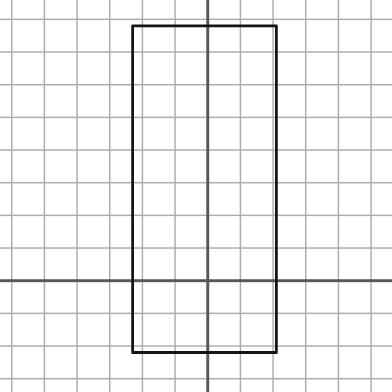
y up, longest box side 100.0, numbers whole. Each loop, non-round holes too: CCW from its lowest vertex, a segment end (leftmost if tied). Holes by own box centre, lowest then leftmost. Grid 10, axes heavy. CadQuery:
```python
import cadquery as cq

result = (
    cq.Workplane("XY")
    .moveTo(-23.0, -22.0)
    .lineTo(21.0, -22.0)
    .lineTo(21.0, 78.0)
    .lineTo(-23.0, 78.0)
    .close()
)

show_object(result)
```